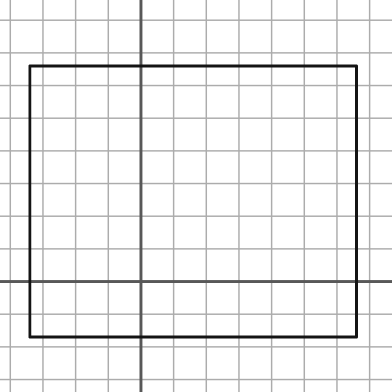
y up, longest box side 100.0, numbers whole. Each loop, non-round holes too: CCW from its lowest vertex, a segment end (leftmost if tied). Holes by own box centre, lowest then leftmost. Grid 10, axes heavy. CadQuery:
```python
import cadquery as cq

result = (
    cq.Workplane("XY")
    .moveTo(-34.0, -17.0)
    .lineTo(66.0, -17.0)
    .lineTo(66.0, 66.0)
    .lineTo(-34.0, 66.0)
    .close()
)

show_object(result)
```